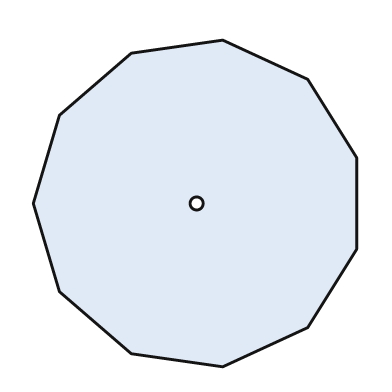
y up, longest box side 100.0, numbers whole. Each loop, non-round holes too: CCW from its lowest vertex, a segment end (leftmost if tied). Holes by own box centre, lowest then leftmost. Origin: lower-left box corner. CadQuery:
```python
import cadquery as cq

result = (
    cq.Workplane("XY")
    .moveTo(58.0, 0.0)
    .lineTo(84.0, 12.0)
    .lineTo(99.0, 36.0)
    .lineTo(99.0, 64.0)
    .lineTo(84.0, 88.0)
    .lineTo(58.0, 100.0)
    .lineTo(30.0, 96.0)
    .lineTo(8.0, 77.0)
    .lineTo(0.0, 50.0)
    .lineTo(8.0, 23.0)
    .lineTo(30.0, 4.0)
    .close()
    .moveTo(50.0, 50.0)
    .circle(2.0)
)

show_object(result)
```